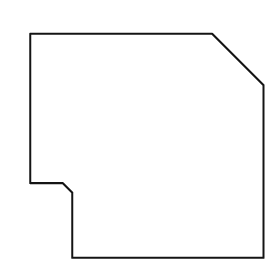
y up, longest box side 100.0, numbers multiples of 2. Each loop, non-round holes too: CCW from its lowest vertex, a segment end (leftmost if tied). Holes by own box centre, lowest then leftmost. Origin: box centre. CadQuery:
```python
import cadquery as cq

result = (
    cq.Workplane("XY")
    .moveTo(-32.0, -48.0)
    .lineTo(50.0, -48.0)
    .lineTo(50.0, 26.0)
    .lineTo(28.0, 48.0)
    .lineTo(-50.0, 48.0)
    .lineTo(-50.0, -16.0)
    .lineTo(-36.0, -16.0)
    .lineTo(-32.0, -20.0)
    .close()
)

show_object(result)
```